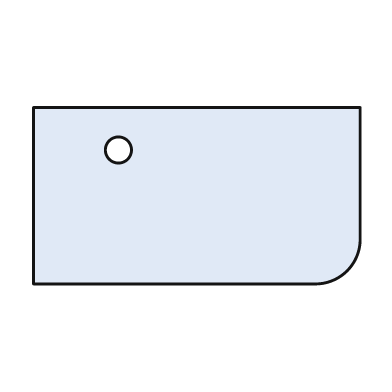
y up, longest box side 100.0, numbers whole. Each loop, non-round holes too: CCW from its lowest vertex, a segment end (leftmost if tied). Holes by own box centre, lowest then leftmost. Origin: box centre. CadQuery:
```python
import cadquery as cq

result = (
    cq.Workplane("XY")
    .moveTo(-50.0, -27.0)
    .lineTo(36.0, -27.0)
    .threePointArc((46.0, -23.0), (50.0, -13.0))
    .lineTo(50.0, 27.0)
    .lineTo(-50.0, 27.0)
    .close()
    .moveTo(-24.0, 14.0)
    .circle(4.0)
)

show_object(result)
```